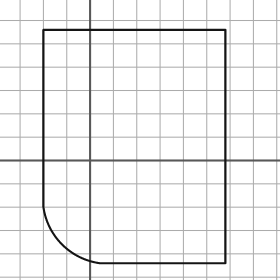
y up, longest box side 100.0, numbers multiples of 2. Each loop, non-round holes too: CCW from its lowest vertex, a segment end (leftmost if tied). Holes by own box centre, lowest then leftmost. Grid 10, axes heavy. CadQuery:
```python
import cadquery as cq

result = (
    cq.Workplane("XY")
    .moveTo(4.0, -44.0)
    .lineTo(58.0, -44.0)
    .lineTo(58.0, 56.0)
    .lineTo(-20.0, 56.0)
    .lineTo(-20.0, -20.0)
    .threePointArc((-12.0, -36.0), (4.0, -44.0))
    .close()
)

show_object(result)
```